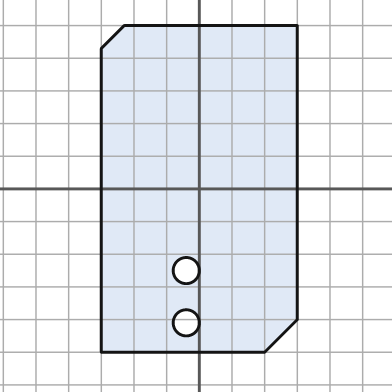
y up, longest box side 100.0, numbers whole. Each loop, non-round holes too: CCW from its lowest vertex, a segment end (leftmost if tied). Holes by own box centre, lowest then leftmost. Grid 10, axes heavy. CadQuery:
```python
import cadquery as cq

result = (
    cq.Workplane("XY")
    .moveTo(-30.0, -50.0)
    .lineTo(20.0, -50.0)
    .lineTo(30.0, -40.0)
    .lineTo(30.0, 50.0)
    .lineTo(-23.0, 50.0)
    .lineTo(-30.0, 43.0)
    .close()
    .moveTo(-4.0, -41.0)
    .circle(4.0)
    .moveTo(-4.0, -25.0)
    .circle(4.0)
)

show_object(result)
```